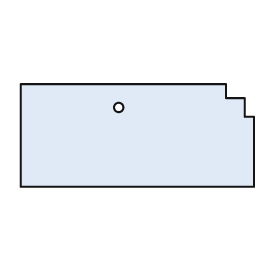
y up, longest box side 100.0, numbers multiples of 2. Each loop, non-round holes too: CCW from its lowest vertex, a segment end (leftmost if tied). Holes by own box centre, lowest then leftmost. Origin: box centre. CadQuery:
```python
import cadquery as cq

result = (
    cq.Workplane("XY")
    .moveTo(-50.0, -22.0)
    .lineTo(50.0, -22.0)
    .lineTo(50.0, 8.0)
    .lineTo(46.0, 8.0)
    .lineTo(46.0, 16.0)
    .lineTo(38.0, 16.0)
    .lineTo(38.0, 22.0)
    .lineTo(-50.0, 22.0)
    .close()
    .moveTo(-8.0, 12.0)
    .circle(2.0)
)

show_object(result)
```